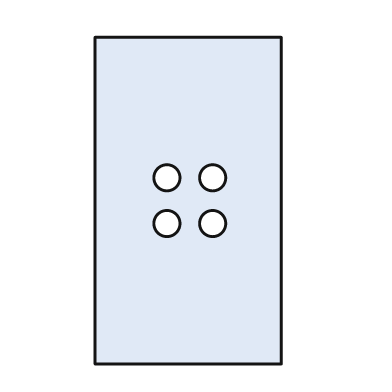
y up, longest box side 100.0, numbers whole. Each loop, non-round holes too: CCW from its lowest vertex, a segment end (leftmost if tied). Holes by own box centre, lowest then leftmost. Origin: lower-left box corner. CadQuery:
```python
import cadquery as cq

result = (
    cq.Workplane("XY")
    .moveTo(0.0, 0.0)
    .lineTo(57.0, 0.0)
    .lineTo(57.0, 100.0)
    .lineTo(0.0, 100.0)
    .close()
    .moveTo(22.0, 43.0)
    .circle(4.0)
    .moveTo(36.0, 43.0)
    .circle(4.0)
    .moveTo(22.0, 57.0)
    .circle(4.0)
    .moveTo(36.0, 57.0)
    .circle(4.0)
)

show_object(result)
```